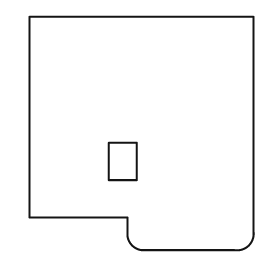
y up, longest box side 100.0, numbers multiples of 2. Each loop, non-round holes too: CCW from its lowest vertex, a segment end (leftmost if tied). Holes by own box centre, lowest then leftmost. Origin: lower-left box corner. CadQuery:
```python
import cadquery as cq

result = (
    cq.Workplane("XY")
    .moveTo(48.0, 0.0)
    .lineTo(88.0, 0.0)
    .threePointArc((94.0, 2.0), (96.0, 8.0))
    .lineTo(96.0, 100.0)
    .lineTo(0.0, 100.0)
    .lineTo(0.0, 14.0)
    .lineTo(42.0, 14.0)
    .lineTo(42.0, 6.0)
    .threePointArc((44.0, 2.0), (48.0, 0.0))
    .close()
    .moveTo(34.0, 30.0)
    .lineTo(46.0, 30.0)
    .lineTo(46.0, 46.0)
    .lineTo(34.0, 46.0)
    .close()
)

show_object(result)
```